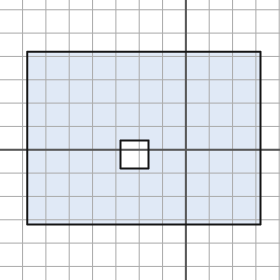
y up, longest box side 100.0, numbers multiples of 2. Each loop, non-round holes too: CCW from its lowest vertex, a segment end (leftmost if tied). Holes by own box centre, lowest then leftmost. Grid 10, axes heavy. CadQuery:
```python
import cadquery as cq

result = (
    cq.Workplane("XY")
    .moveTo(-68.0, -32.0)
    .lineTo(32.0, -32.0)
    .lineTo(32.0, 42.0)
    .lineTo(-68.0, 42.0)
    .close()
    .moveTo(-28.0, -8.0)
    .lineTo(-16.0, -8.0)
    .lineTo(-16.0, 4.0)
    .lineTo(-28.0, 4.0)
    .close()
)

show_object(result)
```